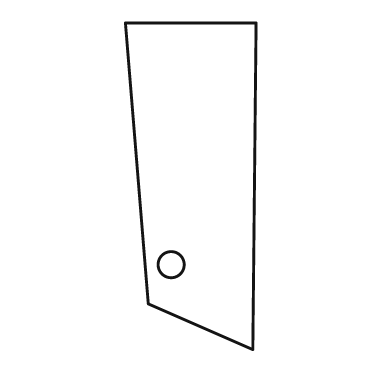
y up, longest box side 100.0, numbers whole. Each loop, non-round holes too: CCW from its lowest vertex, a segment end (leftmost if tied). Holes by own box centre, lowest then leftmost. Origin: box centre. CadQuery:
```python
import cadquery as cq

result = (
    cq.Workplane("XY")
    .moveTo(19.0, -50.0)
    .lineTo(20.0, 50.0)
    .lineTo(-20.0, 50.0)
    .lineTo(-13.0, -36.0)
    .close()
    .moveTo(-6.0, -24.0)
    .circle(4.0)
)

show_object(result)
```